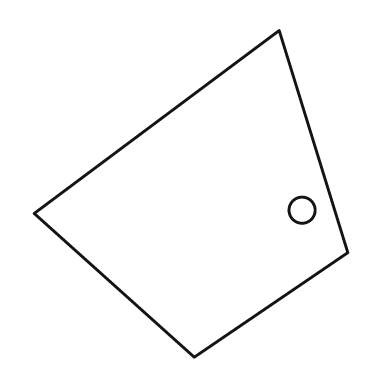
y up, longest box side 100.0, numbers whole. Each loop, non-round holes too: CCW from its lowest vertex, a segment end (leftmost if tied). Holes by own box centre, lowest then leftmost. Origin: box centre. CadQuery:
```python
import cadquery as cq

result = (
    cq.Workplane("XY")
    .moveTo(1.0, -50.0)
    .lineTo(48.0, -18.0)
    .lineTo(27.0, 50.0)
    .lineTo(-48.0, -6.0)
    .close()
    .moveTo(34.0, -5.0)
    .circle(4.0)
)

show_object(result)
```